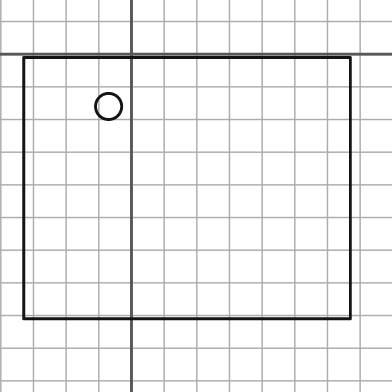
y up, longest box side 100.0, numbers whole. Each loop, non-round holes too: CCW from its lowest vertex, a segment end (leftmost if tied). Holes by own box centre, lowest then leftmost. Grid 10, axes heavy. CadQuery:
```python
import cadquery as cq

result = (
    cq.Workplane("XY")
    .moveTo(-33.0, -81.0)
    .lineTo(67.0, -81.0)
    .lineTo(67.0, -1.0)
    .lineTo(-33.0, -1.0)
    .close()
    .moveTo(-7.0, -16.0)
    .circle(4.0)
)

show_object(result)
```